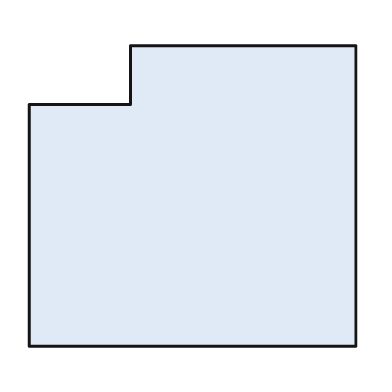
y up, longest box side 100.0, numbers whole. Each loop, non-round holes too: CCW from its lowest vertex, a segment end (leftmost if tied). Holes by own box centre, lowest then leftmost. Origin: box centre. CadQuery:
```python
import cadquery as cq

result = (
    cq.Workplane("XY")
    .moveTo(-50.0, -46.0)
    .lineTo(50.0, -46.0)
    .lineTo(50.0, 46.0)
    .lineTo(-19.0, 46.0)
    .lineTo(-19.0, 28.0)
    .lineTo(-50.0, 28.0)
    .close()
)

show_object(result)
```